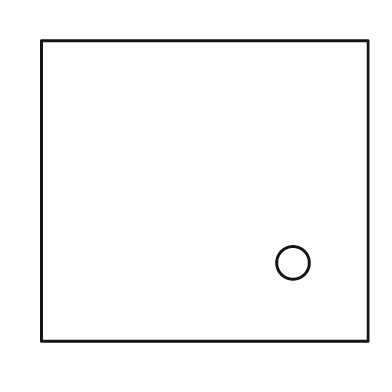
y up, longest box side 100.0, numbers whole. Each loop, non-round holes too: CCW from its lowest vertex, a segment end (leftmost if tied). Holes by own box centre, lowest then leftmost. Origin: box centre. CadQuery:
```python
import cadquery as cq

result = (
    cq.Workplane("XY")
    .moveTo(-50.0, -46.0)
    .lineTo(50.0, -46.0)
    .lineTo(50.0, 46.0)
    .lineTo(-50.0, 46.0)
    .close()
    .moveTo(27.0, -22.0)
    .circle(5.0)
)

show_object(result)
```